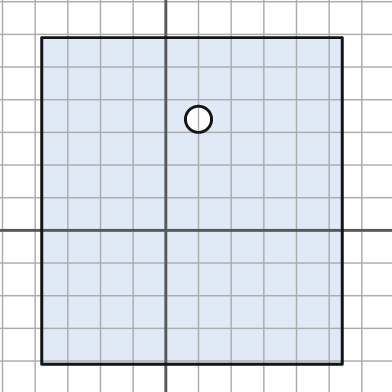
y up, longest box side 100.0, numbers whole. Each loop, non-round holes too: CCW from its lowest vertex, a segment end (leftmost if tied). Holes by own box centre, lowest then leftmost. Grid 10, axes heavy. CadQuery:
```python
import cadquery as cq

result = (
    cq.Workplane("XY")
    .moveTo(-38.0, -41.0)
    .lineTo(54.0, -41.0)
    .lineTo(54.0, 59.0)
    .lineTo(-38.0, 59.0)
    .close()
    .moveTo(10.0, 34.0)
    .circle(4.0)
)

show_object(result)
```